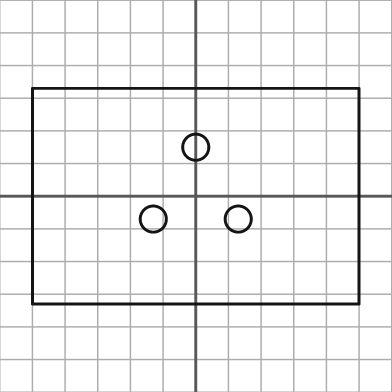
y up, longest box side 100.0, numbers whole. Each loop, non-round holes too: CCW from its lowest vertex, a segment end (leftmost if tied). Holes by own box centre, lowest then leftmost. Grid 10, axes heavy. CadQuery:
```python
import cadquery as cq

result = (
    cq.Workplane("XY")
    .moveTo(-50.0, -33.0)
    .lineTo(50.0, -33.0)
    .lineTo(50.0, 33.0)
    .lineTo(-50.0, 33.0)
    .close()
    .moveTo(-13.0, -7.0)
    .circle(4.0)
    .moveTo(13.0, -7.0)
    .circle(4.0)
    .moveTo(0.0, 15.0)
    .circle(4.0)
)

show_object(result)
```